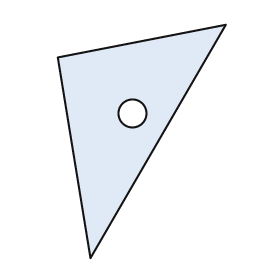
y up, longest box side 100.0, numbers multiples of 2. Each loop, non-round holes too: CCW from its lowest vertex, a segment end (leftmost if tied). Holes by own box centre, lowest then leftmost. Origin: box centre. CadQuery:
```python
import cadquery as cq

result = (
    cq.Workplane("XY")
    .moveTo(-22.0, -50.0)
    .lineTo(36.0, 50.0)
    .lineTo(-36.0, 36.0)
    .close()
    .moveTo(-4.0, 12.0)
    .circle(6.0)
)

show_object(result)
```